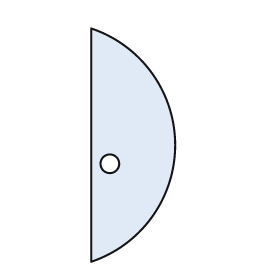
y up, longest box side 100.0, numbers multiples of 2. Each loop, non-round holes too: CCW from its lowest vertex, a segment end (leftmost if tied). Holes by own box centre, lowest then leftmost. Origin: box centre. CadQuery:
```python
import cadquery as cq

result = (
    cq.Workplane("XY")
    .moveTo(-18.0, -50.0)
    .threePointArc((18.0, 0.0), (-18.0, 50.0))
    .close()
    .moveTo(-10.0, -8.0)
    .circle(4.0)
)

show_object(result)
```